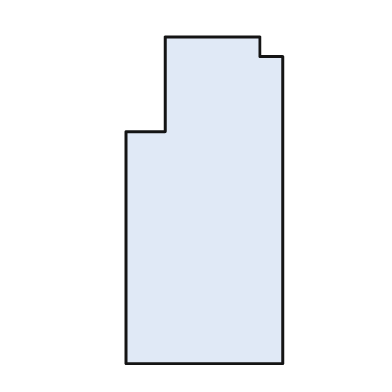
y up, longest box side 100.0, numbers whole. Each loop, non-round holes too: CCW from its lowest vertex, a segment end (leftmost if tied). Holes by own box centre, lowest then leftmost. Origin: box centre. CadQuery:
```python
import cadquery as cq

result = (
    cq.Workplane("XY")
    .moveTo(-24.0, -50.0)
    .lineTo(24.0, -50.0)
    .lineTo(24.0, 44.0)
    .lineTo(17.0, 44.0)
    .lineTo(17.0, 50.0)
    .lineTo(-12.0, 50.0)
    .lineTo(-12.0, 21.0)
    .lineTo(-24.0, 21.0)
    .close()
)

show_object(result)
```